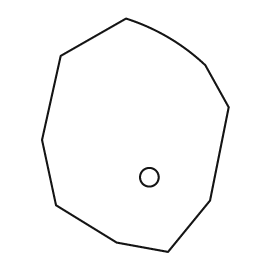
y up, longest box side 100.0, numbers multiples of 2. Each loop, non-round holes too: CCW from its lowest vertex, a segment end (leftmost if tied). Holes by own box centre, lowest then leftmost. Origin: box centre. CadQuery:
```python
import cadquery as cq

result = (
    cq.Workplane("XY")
    .moveTo(14.0, -50.0)
    .lineTo(32.0, -28.0)
    .lineTo(40.0, 12.0)
    .lineTo(30.0, 30.0)
    .threePointArc((14.0, 42.0), (-4.0, 50.0))
    .lineTo(-32.0, 34.0)
    .lineTo(-40.0, -2.0)
    .lineTo(-34.0, -30.0)
    .lineTo(-8.0, -46.0)
    .close()
    .moveTo(6.0, -18.0)
    .circle(4.0)
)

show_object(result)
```